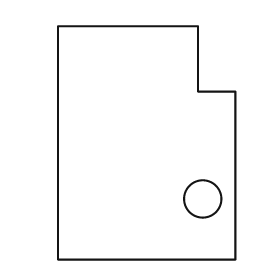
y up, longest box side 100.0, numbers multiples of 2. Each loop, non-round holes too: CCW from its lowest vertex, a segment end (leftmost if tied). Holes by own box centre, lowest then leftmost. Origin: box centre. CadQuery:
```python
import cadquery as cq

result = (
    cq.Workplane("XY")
    .moveTo(-38.0, -50.0)
    .lineTo(38.0, -50.0)
    .lineTo(38.0, 22.0)
    .lineTo(22.0, 22.0)
    .lineTo(22.0, 50.0)
    .lineTo(-38.0, 50.0)
    .close()
    .moveTo(24.0, -24.0)
    .circle(8.0)
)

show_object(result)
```